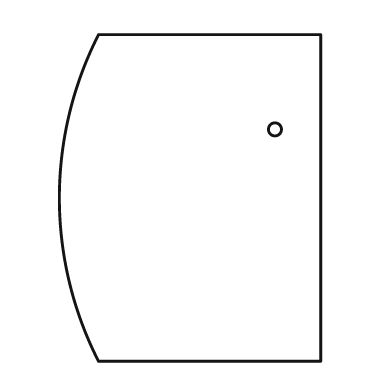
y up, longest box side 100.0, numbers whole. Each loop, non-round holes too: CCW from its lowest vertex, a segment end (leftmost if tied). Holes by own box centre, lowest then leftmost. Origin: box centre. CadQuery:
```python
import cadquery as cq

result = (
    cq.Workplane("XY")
    .moveTo(-28.0, -50.0)
    .lineTo(40.0, -50.0)
    .lineTo(40.0, 50.0)
    .lineTo(-28.0, 50.0)
    .threePointArc((-40.0, 0.0), (-28.0, -50.0))
    .close()
    .moveTo(26.0, 21.0)
    .circle(2.0)
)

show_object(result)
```